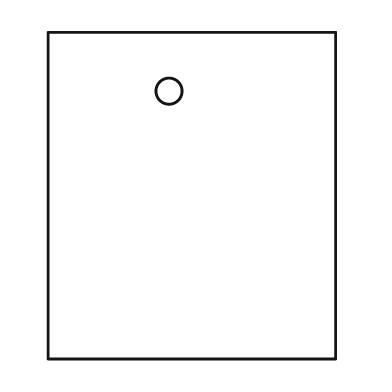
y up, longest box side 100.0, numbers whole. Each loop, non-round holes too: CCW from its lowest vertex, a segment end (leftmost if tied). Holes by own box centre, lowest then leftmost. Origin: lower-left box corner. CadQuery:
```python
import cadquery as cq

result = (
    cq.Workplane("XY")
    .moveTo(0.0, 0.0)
    .lineTo(88.0, 0.0)
    .lineTo(88.0, 100.0)
    .lineTo(0.0, 100.0)
    .close()
    .moveTo(37.0, 82.0)
    .circle(4.0)
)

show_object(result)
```